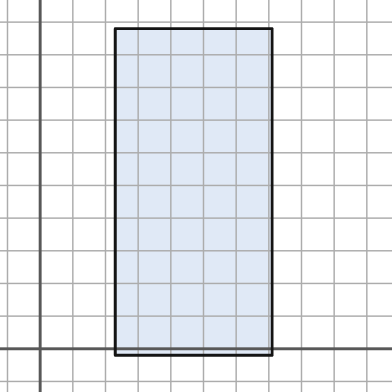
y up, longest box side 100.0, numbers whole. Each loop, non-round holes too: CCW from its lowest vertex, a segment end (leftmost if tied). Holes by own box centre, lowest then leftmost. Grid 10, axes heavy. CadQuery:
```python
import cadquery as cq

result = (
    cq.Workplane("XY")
    .moveTo(23.0, -2.0)
    .lineTo(71.0, -2.0)
    .lineTo(71.0, 98.0)
    .lineTo(23.0, 98.0)
    .close()
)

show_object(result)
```